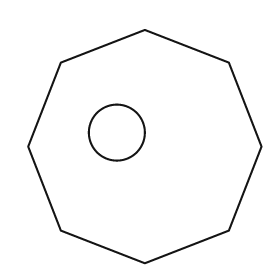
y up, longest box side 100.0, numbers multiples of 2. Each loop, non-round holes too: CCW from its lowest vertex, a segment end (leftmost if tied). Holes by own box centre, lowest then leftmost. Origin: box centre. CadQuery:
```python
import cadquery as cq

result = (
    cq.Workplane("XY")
    .moveTo(0.0, -50.0)
    .lineTo(36.0, -36.0)
    .lineTo(50.0, 0.0)
    .lineTo(36.0, 36.0)
    .lineTo(0.0, 50.0)
    .lineTo(-36.0, 36.0)
    .lineTo(-50.0, 0.0)
    .lineTo(-36.0, -36.0)
    .close()
    .moveTo(-12.0, 6.0)
    .circle(12.0)
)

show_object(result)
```